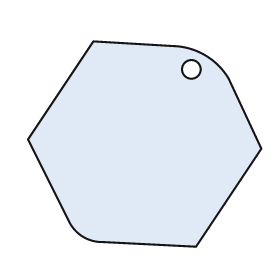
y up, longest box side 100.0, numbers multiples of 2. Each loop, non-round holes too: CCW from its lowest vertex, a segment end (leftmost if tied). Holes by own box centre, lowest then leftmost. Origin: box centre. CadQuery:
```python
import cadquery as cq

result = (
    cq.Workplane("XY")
    .moveTo(22.0, -44.0)
    .lineTo(50.0, -2.0)
    .lineTo(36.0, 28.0)
    .threePointArc((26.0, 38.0), (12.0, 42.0))
    .lineTo(-22.0, 44.0)
    .lineTo(-50.0, 2.0)
    .lineTo(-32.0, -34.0)
    .threePointArc((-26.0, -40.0), (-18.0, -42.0))
    .close()
    .moveTo(20.0, 32.0)
    .circle(4.0)
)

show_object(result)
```